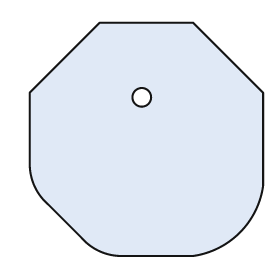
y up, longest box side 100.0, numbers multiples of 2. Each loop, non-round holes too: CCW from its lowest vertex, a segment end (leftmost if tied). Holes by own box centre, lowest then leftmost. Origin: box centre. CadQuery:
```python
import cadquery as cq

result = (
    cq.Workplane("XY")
    .moveTo(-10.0, -50.0)
    .lineTo(20.0, -50.0)
    .threePointArc((40.0, -40.0), (50.0, -20.0))
    .lineTo(50.0, 20.0)
    .lineTo(20.0, 50.0)
    .lineTo(-20.0, 50.0)
    .lineTo(-50.0, 20.0)
    .lineTo(-50.0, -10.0)
    .threePointArc((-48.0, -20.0), (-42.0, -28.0))
    .lineTo(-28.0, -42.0)
    .threePointArc((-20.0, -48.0), (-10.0, -50.0))
    .close()
    .moveTo(-2.0, 18.0)
    .circle(4.0)
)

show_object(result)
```